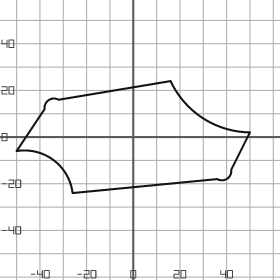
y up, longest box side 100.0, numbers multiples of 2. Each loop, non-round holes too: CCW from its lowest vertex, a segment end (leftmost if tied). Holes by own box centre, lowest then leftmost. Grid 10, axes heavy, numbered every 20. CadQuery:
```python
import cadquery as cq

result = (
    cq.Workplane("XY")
    .moveTo(-26.0, -24.0)
    .lineTo(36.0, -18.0)
    .threePointArc((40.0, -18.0), (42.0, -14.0))
    .lineTo(50.0, 2.0)
    .threePointArc((30.0, 8.0), (16.0, 24.0))
    .lineTo(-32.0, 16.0)
    .threePointArc((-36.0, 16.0), (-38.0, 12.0))
    .lineTo(-50.0, -6.0)
    .threePointArc((-34.0, -10.0), (-26.0, -24.0))
    .close()
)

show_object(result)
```